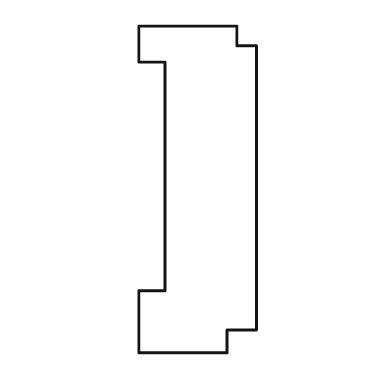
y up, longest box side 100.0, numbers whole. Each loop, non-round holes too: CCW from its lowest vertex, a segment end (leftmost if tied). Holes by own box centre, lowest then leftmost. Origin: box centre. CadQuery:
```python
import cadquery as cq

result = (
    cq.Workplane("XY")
    .moveTo(-18.0, -50.0)
    .lineTo(9.0, -50.0)
    .lineTo(9.0, -43.0)
    .lineTo(18.0, -43.0)
    .lineTo(18.0, 44.0)
    .lineTo(12.0, 44.0)
    .lineTo(12.0, 50.0)
    .lineTo(-18.0, 50.0)
    .lineTo(-18.0, 39.0)
    .lineTo(-10.0, 39.0)
    .lineTo(-10.0, -31.0)
    .lineTo(-18.0, -31.0)
    .close()
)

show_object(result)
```